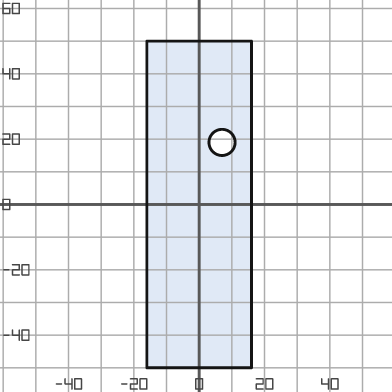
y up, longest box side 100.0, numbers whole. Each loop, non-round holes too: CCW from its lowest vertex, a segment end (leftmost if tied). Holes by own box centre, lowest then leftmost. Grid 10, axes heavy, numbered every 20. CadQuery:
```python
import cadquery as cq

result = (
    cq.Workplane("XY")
    .moveTo(-16.0, -50.0)
    .lineTo(16.0, -50.0)
    .lineTo(16.0, 50.0)
    .lineTo(-16.0, 50.0)
    .close()
    .moveTo(7.0, 19.0)
    .circle(4.0)
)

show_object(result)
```